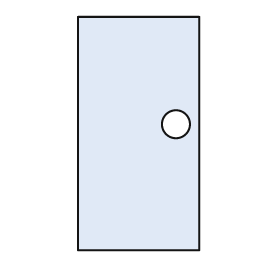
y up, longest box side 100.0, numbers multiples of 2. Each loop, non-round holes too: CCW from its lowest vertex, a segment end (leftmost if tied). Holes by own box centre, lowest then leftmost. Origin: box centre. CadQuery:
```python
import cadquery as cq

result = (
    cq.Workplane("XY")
    .moveTo(-26.0, -50.0)
    .lineTo(26.0, -50.0)
    .lineTo(26.0, 50.0)
    .lineTo(-26.0, 50.0)
    .close()
    .moveTo(16.0, 4.0)
    .circle(6.0)
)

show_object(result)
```